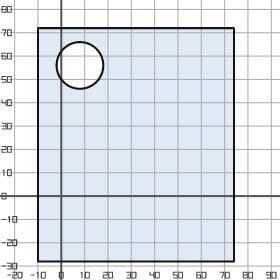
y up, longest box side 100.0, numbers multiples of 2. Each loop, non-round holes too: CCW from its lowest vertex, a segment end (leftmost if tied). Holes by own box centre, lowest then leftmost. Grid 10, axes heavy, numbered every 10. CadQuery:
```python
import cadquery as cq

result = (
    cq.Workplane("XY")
    .moveTo(-10.0, -28.0)
    .lineTo(74.0, -28.0)
    .lineTo(74.0, 72.0)
    .lineTo(-10.0, 72.0)
    .close()
    .moveTo(8.0, 56.0)
    .circle(10.0)
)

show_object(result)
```